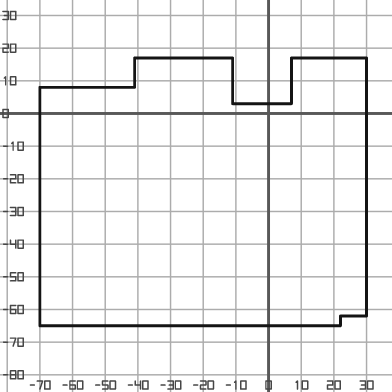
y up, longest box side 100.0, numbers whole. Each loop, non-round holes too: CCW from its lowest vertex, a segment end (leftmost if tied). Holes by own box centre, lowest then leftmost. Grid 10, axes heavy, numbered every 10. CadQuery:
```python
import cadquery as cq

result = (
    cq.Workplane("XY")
    .moveTo(-70.0, -65.0)
    .lineTo(22.0, -65.0)
    .lineTo(22.0, -62.0)
    .lineTo(30.0, -62.0)
    .lineTo(30.0, 17.0)
    .lineTo(7.0, 17.0)
    .lineTo(7.0, 3.0)
    .lineTo(-11.0, 3.0)
    .lineTo(-11.0, 17.0)
    .lineTo(-41.0, 17.0)
    .lineTo(-41.0, 8.0)
    .lineTo(-70.0, 8.0)
    .close()
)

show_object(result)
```